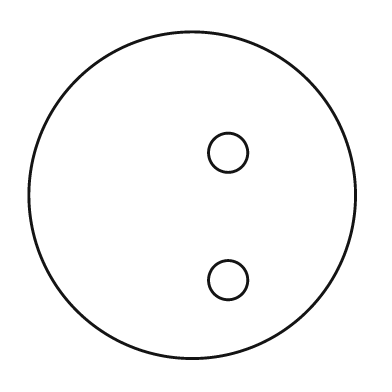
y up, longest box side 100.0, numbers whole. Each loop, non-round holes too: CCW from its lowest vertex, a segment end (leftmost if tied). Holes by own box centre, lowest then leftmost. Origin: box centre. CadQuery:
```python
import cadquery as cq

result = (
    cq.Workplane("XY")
    .moveTo(0.0, 0.0)
    .circle(50.0)
    .moveTo(11.0, -26.0)
    .circle(6.0)
    .moveTo(11.0, 13.0)
    .circle(6.0)
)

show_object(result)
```